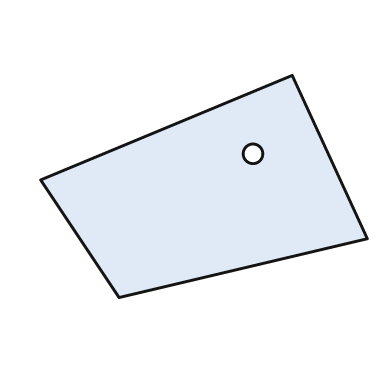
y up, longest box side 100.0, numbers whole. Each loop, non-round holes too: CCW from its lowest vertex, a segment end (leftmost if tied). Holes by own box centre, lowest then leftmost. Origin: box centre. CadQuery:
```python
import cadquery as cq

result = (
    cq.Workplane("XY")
    .moveTo(-26.0, -34.0)
    .lineTo(50.0, -16.0)
    .lineTo(27.0, 34.0)
    .lineTo(-50.0, 2.0)
    .close()
    .moveTo(15.0, 10.0)
    .circle(3.0)
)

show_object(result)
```